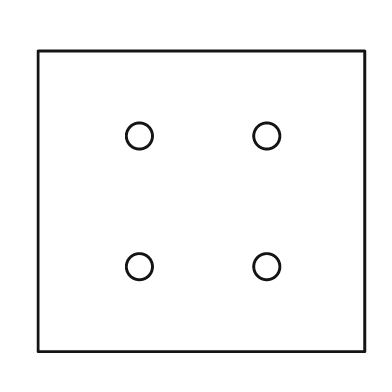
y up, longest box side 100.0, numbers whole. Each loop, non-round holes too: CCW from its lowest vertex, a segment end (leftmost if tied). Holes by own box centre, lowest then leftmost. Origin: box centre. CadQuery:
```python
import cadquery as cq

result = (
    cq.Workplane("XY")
    .moveTo(-50.0, -46.0)
    .lineTo(50.0, -46.0)
    .lineTo(50.0, 46.0)
    .lineTo(-50.0, 46.0)
    .close()
    .moveTo(-19.0, -20.0)
    .circle(4.0)
    .moveTo(20.0, -20.0)
    .circle(4.0)
    .moveTo(-19.0, 20.0)
    .circle(4.0)
    .moveTo(20.0, 20.0)
    .circle(4.0)
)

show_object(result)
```